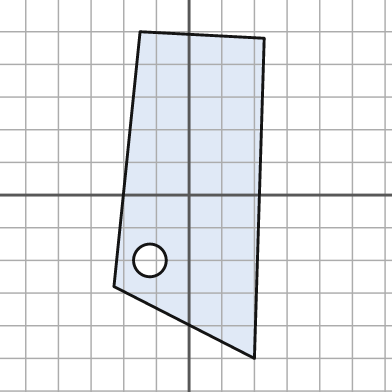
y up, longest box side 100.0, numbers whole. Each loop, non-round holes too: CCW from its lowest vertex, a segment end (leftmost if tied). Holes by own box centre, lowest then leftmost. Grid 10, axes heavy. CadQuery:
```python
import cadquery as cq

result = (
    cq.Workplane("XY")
    .moveTo(20.0, -50.0)
    .lineTo(23.0, 48.0)
    .lineTo(-15.0, 50.0)
    .lineTo(-23.0, -28.0)
    .close()
    .moveTo(-12.0, -20.0)
    .circle(5.0)
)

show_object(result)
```